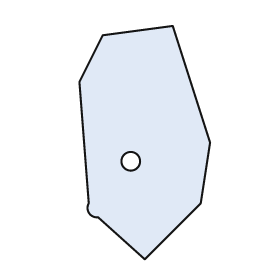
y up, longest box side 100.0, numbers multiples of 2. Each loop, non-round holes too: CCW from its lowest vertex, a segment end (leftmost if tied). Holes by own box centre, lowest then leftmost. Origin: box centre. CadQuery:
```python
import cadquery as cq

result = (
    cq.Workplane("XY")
    .moveTo(0.0, -50.0)
    .lineTo(24.0, -26.0)
    .lineTo(28.0, 0.0)
    .lineTo(12.0, 50.0)
    .lineTo(-18.0, 46.0)
    .lineTo(-28.0, 26.0)
    .lineTo(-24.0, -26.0)
    .threePointArc((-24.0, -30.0), (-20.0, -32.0))
    .close()
    .moveTo(-6.0, -8.0)
    .circle(4.0)
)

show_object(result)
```